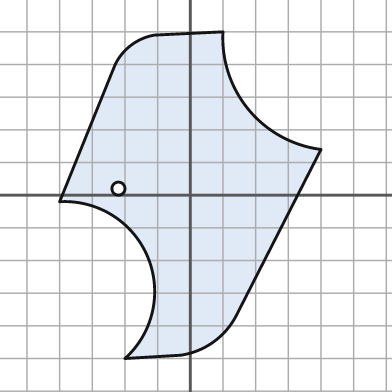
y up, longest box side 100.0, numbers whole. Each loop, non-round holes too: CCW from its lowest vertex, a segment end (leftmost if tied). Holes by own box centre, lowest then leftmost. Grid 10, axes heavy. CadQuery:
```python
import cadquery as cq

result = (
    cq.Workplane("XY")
    .moveTo(-20.0, -50.0)
    .lineTo(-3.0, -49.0)
    .threePointArc((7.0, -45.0), (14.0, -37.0))
    .lineTo(40.0, 14.0)
    .threePointArc((18.0, 26.0), (10.0, 50.0))
    .lineTo(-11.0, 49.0)
    .threePointArc((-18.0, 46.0), (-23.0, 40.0))
    .lineTo(-40.0, -2.0)
    .threePointArc((-13.0, -19.0), (-20.0, -50.0))
    .close()
    .moveTo(-22.0, 2.0)
    .circle(2.0)
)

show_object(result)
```